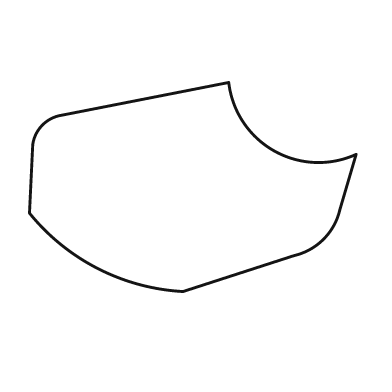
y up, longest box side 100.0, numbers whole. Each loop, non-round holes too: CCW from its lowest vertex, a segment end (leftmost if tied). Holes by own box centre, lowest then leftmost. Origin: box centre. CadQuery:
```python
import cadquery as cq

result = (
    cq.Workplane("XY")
    .moveTo(-3.0, -32.0)
    .lineTo(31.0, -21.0)
    .threePointArc((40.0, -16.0), (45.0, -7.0))
    .lineTo(50.0, 10.0)
    .threePointArc((25.0, 11.0), (11.0, 32.0))
    .lineTo(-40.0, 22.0)
    .threePointArc((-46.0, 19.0), (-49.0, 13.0))
    .lineTo(-50.0, -8.0)
    .threePointArc((-29.0, -25.0), (-3.0, -32.0))
    .close()
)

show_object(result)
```